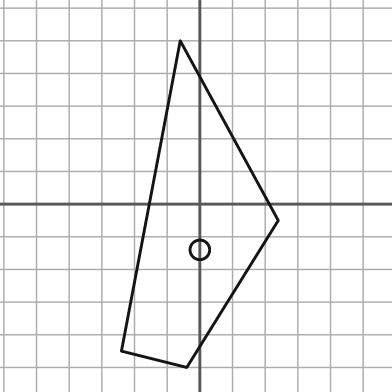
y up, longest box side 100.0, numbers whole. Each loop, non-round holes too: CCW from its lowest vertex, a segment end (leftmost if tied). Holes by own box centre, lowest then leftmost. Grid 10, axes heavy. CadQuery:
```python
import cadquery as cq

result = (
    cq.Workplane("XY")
    .moveTo(-4.0, -50.0)
    .lineTo(24.0, -5.0)
    .lineTo(-6.0, 50.0)
    .lineTo(-24.0, -45.0)
    .close()
    .moveTo(0.0, -14.0)
    .circle(3.0)
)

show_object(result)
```